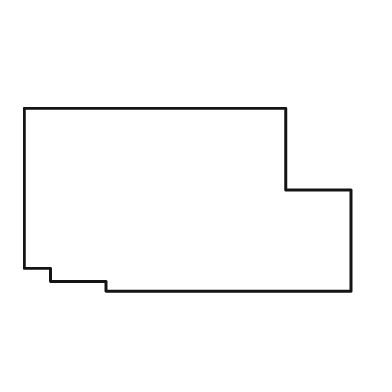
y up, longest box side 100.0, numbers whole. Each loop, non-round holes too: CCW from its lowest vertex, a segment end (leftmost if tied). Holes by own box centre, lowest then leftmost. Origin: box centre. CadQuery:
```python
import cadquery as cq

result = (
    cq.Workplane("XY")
    .moveTo(-25.0, -28.0)
    .lineTo(50.0, -28.0)
    .lineTo(50.0, 3.0)
    .lineTo(30.0, 3.0)
    .lineTo(30.0, 28.0)
    .lineTo(-50.0, 28.0)
    .lineTo(-50.0, -21.0)
    .lineTo(-42.0, -21.0)
    .lineTo(-42.0, -25.0)
    .lineTo(-25.0, -25.0)
    .close()
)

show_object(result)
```